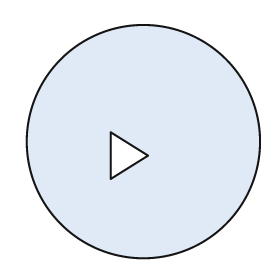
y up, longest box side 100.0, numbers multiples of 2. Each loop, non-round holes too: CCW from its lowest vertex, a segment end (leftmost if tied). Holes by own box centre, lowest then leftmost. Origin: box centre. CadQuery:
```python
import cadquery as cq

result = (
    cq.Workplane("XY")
    .moveTo(0.0, 0.0)
    .circle(50.0)
    .moveTo(-14.0, -16.0)
    .lineTo(2.0, -6.0)
    .lineTo(-14.0, 4.0)
    .close()
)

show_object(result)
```